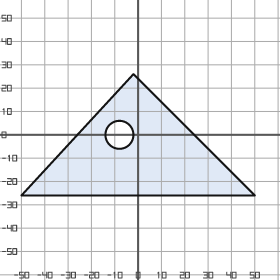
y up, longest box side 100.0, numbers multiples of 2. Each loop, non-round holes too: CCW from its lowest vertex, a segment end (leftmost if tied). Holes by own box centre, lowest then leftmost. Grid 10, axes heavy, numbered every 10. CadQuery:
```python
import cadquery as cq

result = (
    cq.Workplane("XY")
    .moveTo(-50.0, -26.0)
    .lineTo(50.0, -26.0)
    .lineTo(-2.0, 26.0)
    .close()
    .moveTo(-8.0, 0.0)
    .circle(6.0)
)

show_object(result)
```